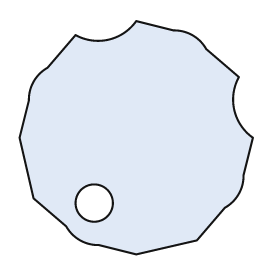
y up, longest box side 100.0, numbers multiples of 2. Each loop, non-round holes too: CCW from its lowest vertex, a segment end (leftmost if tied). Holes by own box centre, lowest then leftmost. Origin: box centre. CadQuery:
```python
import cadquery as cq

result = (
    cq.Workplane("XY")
    .moveTo(0.0, -50.0)
    .lineTo(26.0, -44.0)
    .lineTo(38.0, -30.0)
    .threePointArc((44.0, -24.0), (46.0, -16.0))
    .lineTo(50.0, 0.0)
    .threePointArc((42.0, 12.0), (44.0, 26.0))
    .lineTo(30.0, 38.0)
    .threePointArc((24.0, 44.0), (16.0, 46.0))
    .lineTo(0.0, 50.0)
    .threePointArc((-12.0, 42.0), (-26.0, 44.0))
    .lineTo(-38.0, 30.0)
    .threePointArc((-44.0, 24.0), (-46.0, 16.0))
    .lineTo(-50.0, 0.0)
    .lineTo(-44.0, -26.0)
    .lineTo(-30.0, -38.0)
    .threePointArc((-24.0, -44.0), (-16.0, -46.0))
    .close()
    .moveTo(-18.0, -28.0)
    .circle(8.0)
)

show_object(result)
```